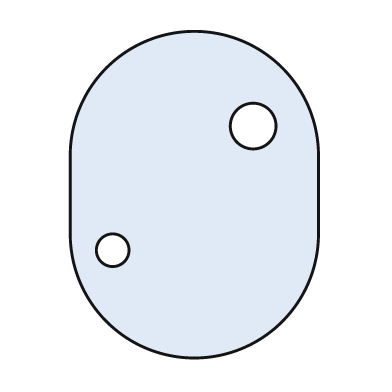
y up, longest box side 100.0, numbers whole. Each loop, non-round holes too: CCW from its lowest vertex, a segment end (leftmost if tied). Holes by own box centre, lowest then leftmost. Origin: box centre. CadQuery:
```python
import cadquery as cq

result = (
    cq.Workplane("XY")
    .moveTo(-38.0, -12.0)
    .threePointArc((0.0, -50.0), (38.0, -12.0))
    .lineTo(38.0, 12.0)
    .threePointArc((0.0, 50.0), (-38.0, 12.0))
    .close()
    .moveTo(-25.0, -17.0)
    .circle(5.0)
    .moveTo(18.0, 21.0)
    .circle(7.0)
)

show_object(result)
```